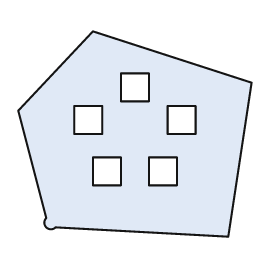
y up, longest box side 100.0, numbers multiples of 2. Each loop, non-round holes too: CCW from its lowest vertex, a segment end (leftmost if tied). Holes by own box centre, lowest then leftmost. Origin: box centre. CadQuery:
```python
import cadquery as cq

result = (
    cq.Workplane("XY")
    .moveTo(40.0, -44.0)
    .lineTo(50.0, 22.0)
    .lineTo(-18.0, 44.0)
    .lineTo(-50.0, 10.0)
    .lineTo(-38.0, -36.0)
    .threePointArc((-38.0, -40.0), (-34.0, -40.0))
    .close()
    .moveTo(-18.0, -22.0)
    .lineTo(-6.0, -22.0)
    .lineTo(-6.0, -10.0)
    .lineTo(-18.0, -10.0)
    .close()
    .moveTo(6.0, -22.0)
    .lineTo(18.0, -22.0)
    .lineTo(18.0, -10.0)
    .lineTo(6.0, -10.0)
    .close()
    .moveTo(-26.0, 0.0)
    .lineTo(-14.0, 0.0)
    .lineTo(-14.0, 12.0)
    .lineTo(-26.0, 12.0)
    .close()
    .moveTo(14.0, 0.0)
    .lineTo(26.0, 0.0)
    .lineTo(26.0, 12.0)
    .lineTo(14.0, 12.0)
    .close()
    .moveTo(-6.0, 14.0)
    .lineTo(6.0, 14.0)
    .lineTo(6.0, 26.0)
    .lineTo(-6.0, 26.0)
    .close()
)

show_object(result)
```